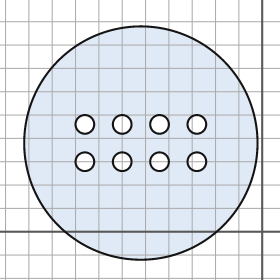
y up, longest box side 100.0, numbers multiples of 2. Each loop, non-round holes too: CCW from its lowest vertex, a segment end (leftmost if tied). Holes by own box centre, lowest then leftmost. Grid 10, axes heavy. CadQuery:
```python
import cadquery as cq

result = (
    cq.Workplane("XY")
    .moveTo(-52.0, 38.0)
    .circle(50.0)
    .moveTo(-76.0, 30.0)
    .circle(4.0)
    .moveTo(-60.0, 30.0)
    .circle(4.0)
    .moveTo(-44.0, 30.0)
    .circle(4.0)
    .moveTo(-28.0, 30.0)
    .circle(4.0)
    .moveTo(-76.0, 46.0)
    .circle(4.0)
    .moveTo(-60.0, 46.0)
    .circle(4.0)
    .moveTo(-44.0, 46.0)
    .circle(4.0)
    .moveTo(-28.0, 46.0)
    .circle(4.0)
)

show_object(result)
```